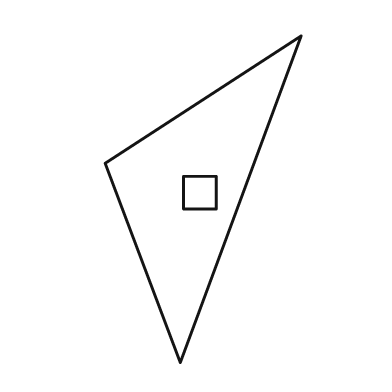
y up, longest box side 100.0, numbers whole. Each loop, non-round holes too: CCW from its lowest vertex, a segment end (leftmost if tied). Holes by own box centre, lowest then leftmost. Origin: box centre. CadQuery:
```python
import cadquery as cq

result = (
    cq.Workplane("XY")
    .moveTo(-7.0, -50.0)
    .lineTo(30.0, 50.0)
    .lineTo(-30.0, 11.0)
    .close()
    .moveTo(-6.0, -3.0)
    .lineTo(4.0, -3.0)
    .lineTo(4.0, 7.0)
    .lineTo(-6.0, 7.0)
    .close()
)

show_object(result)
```